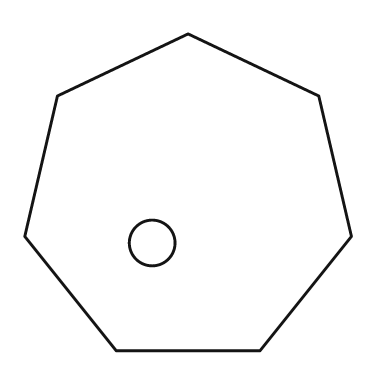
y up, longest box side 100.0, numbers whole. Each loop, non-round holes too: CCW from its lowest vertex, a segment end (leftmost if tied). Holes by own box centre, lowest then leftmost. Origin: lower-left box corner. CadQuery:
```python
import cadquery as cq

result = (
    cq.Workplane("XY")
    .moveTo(28.0, 0.0)
    .lineTo(72.0, 0.0)
    .lineTo(100.0, 35.0)
    .lineTo(90.0, 78.0)
    .lineTo(50.0, 97.0)
    .lineTo(10.0, 78.0)
    .lineTo(0.0, 35.0)
    .close()
    .moveTo(39.0, 33.0)
    .circle(7.0)
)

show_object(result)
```